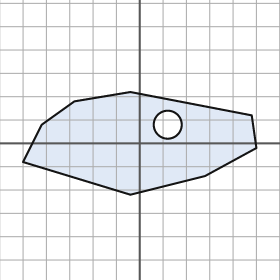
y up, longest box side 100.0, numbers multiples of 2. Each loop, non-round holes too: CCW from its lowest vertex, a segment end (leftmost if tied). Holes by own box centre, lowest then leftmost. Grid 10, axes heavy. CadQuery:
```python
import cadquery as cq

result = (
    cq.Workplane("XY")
    .moveTo(-4.0, -22.0)
    .lineTo(28.0, -14.0)
    .lineTo(50.0, -2.0)
    .lineTo(48.0, 12.0)
    .lineTo(-4.0, 22.0)
    .lineTo(-28.0, 18.0)
    .lineTo(-42.0, 8.0)
    .lineTo(-50.0, -8.0)
    .close()
    .moveTo(12.0, 8.0)
    .circle(6.0)
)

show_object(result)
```